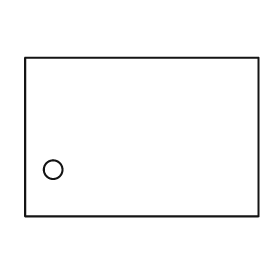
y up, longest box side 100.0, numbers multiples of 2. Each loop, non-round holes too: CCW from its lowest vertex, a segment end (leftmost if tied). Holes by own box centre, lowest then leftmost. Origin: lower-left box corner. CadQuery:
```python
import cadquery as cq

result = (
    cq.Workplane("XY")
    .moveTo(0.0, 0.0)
    .lineTo(100.0, 0.0)
    .lineTo(100.0, 68.0)
    .lineTo(0.0, 68.0)
    .close()
    .moveTo(12.0, 20.0)
    .circle(4.0)
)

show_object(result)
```